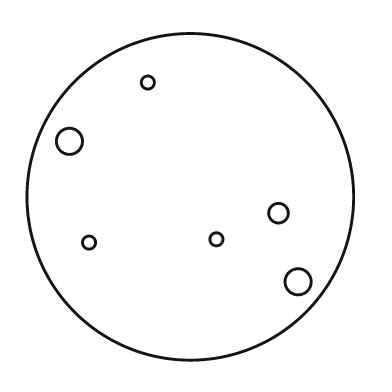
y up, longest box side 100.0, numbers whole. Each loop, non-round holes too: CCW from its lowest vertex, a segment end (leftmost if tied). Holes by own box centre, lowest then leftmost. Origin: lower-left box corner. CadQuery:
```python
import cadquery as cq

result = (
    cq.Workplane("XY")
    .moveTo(50.0, 50.0)
    .circle(50.0)
    .moveTo(83.0, 24.0)
    .circle(4.0)
    .moveTo(19.0, 36.0)
    .circle(2.0)
    .moveTo(58.0, 37.0)
    .circle(2.0)
    .moveTo(77.0, 45.0)
    .circle(3.0)
    .moveTo(13.0, 67.0)
    .circle(4.0)
    .moveTo(37.0, 85.0)
    .circle(2.0)
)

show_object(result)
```